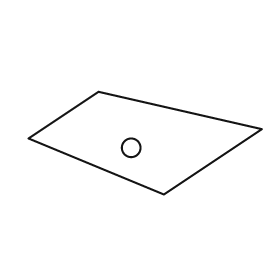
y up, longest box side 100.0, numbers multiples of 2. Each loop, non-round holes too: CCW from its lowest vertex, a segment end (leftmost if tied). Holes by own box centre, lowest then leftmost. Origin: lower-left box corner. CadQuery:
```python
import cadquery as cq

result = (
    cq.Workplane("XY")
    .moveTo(58.0, 0.0)
    .lineTo(100.0, 28.0)
    .lineTo(30.0, 44.0)
    .lineTo(0.0, 24.0)
    .close()
    .moveTo(44.0, 20.0)
    .circle(4.0)
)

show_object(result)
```